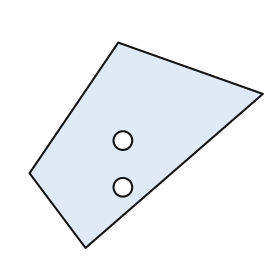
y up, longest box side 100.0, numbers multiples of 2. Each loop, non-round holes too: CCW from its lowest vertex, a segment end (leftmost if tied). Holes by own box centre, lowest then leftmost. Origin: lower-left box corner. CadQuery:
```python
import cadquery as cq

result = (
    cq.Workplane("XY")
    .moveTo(24.0, 0.0)
    .lineTo(100.0, 66.0)
    .lineTo(38.0, 88.0)
    .lineTo(0.0, 32.0)
    .close()
    .moveTo(40.0, 26.0)
    .circle(4.0)
    .moveTo(40.0, 46.0)
    .circle(4.0)
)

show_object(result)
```